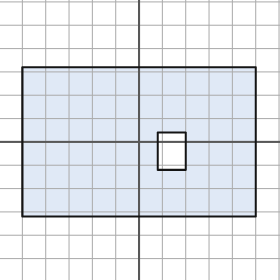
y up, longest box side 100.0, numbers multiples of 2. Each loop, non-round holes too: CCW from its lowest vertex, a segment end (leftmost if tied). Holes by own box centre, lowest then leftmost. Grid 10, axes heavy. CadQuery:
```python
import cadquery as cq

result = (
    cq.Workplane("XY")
    .moveTo(-50.0, -32.0)
    .lineTo(50.0, -32.0)
    .lineTo(50.0, 32.0)
    .lineTo(-50.0, 32.0)
    .close()
    .moveTo(8.0, -12.0)
    .lineTo(20.0, -12.0)
    .lineTo(20.0, 4.0)
    .lineTo(8.0, 4.0)
    .close()
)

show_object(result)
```